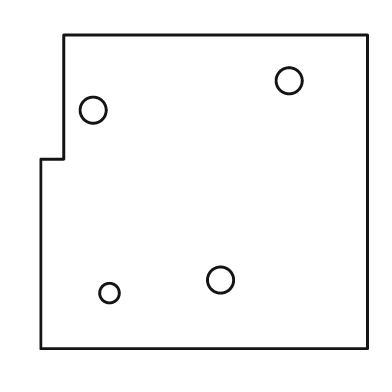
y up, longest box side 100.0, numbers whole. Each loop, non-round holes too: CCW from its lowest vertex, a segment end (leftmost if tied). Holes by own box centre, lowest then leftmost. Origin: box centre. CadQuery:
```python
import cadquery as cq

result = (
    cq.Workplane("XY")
    .moveTo(-50.0, -48.0)
    .lineTo(50.0, -48.0)
    .lineTo(50.0, 48.0)
    .lineTo(-43.0, 48.0)
    .lineTo(-43.0, 10.0)
    .lineTo(-50.0, 10.0)
    .close()
    .moveTo(-29.0, -31.0)
    .circle(3.0)
    .moveTo(5.0, -27.0)
    .circle(4.0)
    .moveTo(-34.0, 25.0)
    .circle(4.0)
    .moveTo(26.0, 34.0)
    .circle(4.0)
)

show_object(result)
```